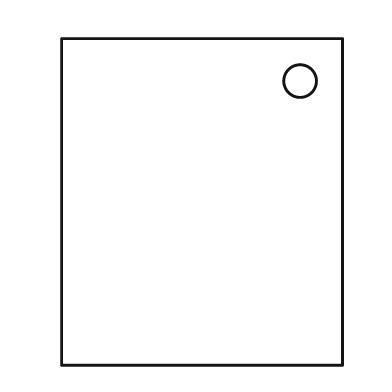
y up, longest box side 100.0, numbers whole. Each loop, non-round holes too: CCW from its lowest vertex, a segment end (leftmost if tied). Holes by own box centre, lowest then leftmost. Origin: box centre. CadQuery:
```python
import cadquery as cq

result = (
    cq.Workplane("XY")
    .moveTo(-43.0, -50.0)
    .lineTo(43.0, -50.0)
    .lineTo(43.0, 50.0)
    .lineTo(-43.0, 50.0)
    .close()
    .moveTo(30.0, 37.0)
    .circle(5.0)
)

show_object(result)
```